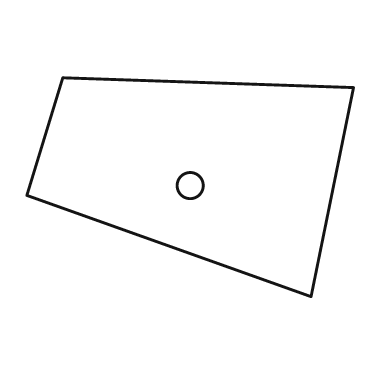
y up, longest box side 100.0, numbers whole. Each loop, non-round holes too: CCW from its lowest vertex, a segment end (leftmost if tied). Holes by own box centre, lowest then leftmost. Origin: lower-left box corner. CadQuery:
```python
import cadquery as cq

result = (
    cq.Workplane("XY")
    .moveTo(87.0, 0.0)
    .lineTo(100.0, 64.0)
    .lineTo(11.0, 67.0)
    .lineTo(0.0, 31.0)
    .close()
    .moveTo(50.0, 34.0)
    .circle(4.0)
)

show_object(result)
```